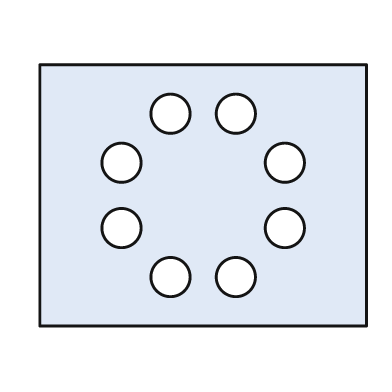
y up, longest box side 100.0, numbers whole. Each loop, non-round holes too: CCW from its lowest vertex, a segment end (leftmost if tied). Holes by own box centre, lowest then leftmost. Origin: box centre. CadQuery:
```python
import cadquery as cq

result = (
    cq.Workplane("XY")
    .moveTo(-50.0, -40.0)
    .lineTo(50.0, -40.0)
    .lineTo(50.0, 40.0)
    .lineTo(-50.0, 40.0)
    .close()
    .moveTo(-10.0, -25.0)
    .circle(6.0)
    .moveTo(10.0, -25.0)
    .circle(6.0)
    .moveTo(-25.0, -10.0)
    .circle(6.0)
    .moveTo(25.0, -10.0)
    .circle(6.0)
    .moveTo(-25.0, 10.0)
    .circle(6.0)
    .moveTo(25.0, 10.0)
    .circle(6.0)
    .moveTo(-10.0, 25.0)
    .circle(6.0)
    .moveTo(10.0, 25.0)
    .circle(6.0)
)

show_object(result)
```